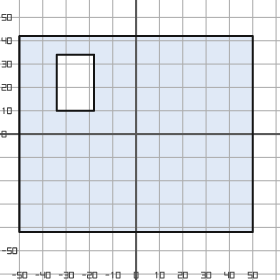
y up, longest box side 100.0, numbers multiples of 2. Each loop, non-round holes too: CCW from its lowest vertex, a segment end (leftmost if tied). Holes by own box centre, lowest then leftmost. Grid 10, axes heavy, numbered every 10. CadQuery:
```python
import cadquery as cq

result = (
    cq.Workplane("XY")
    .moveTo(-50.0, -42.0)
    .lineTo(50.0, -42.0)
    .lineTo(50.0, 42.0)
    .lineTo(-50.0, 42.0)
    .close()
    .moveTo(-34.0, 10.0)
    .lineTo(-18.0, 10.0)
    .lineTo(-18.0, 34.0)
    .lineTo(-34.0, 34.0)
    .close()
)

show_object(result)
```